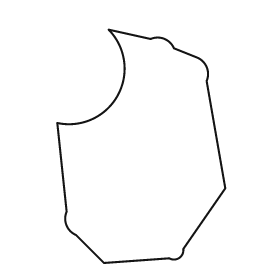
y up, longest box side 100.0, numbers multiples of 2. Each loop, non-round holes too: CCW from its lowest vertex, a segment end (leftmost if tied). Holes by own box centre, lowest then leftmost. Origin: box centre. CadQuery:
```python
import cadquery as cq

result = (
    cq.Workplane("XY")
    .moveTo(-16.0, -50.0)
    .lineTo(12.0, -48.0)
    .threePointArc((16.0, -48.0), (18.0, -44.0))
    .lineTo(36.0, -18.0)
    .lineTo(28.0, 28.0)
    .threePointArc((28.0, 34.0), (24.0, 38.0))
    .lineTo(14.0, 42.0)
    .threePointArc((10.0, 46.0), (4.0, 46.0))
    .lineTo(-14.0, 50.0)
    .threePointArc((-10.0, 22.0), (-36.0, 10.0))
    .lineTo(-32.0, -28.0)
    .threePointArc((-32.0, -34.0), (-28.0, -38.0))
    .close()
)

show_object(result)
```